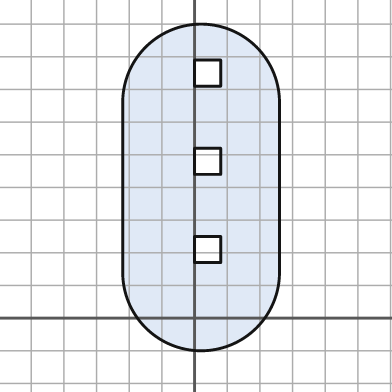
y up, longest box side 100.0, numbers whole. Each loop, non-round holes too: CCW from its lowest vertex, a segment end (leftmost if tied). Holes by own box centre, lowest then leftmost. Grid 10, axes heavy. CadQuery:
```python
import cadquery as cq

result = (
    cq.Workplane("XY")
    .moveTo(-22.0, 14.0)
    .threePointArc((2.0, -10.0), (26.0, 14.0))
    .lineTo(26.0, 66.0)
    .threePointArc((2.0, 90.0), (-22.0, 66.0))
    .close()
    .moveTo(0.0, 17.0)
    .lineTo(8.0, 17.0)
    .lineTo(8.0, 25.0)
    .lineTo(0.0, 25.0)
    .close()
    .moveTo(0.0, 44.0)
    .lineTo(8.0, 44.0)
    .lineTo(8.0, 52.0)
    .lineTo(0.0, 52.0)
    .close()
    .moveTo(0.0, 71.0)
    .lineTo(8.0, 71.0)
    .lineTo(8.0, 79.0)
    .lineTo(0.0, 79.0)
    .close()
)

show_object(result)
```